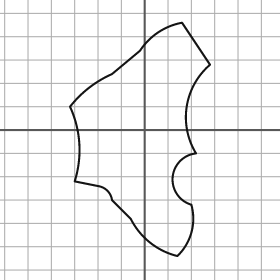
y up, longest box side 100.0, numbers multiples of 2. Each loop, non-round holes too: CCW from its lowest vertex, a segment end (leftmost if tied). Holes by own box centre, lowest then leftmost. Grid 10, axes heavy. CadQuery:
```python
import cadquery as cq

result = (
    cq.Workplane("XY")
    .moveTo(14.0, -54.0)
    .threePointArc((20.0, -44.0), (20.0, -32.0))
    .threePointArc((12.0, -20.0), (22.0, -10.0))
    .threePointArc((18.0, 10.0), (28.0, 28.0))
    .lineTo(16.0, 46.0)
    .threePointArc((6.0, 42.0), (-2.0, 34.0))
    .lineTo(-14.0, 24.0)
    .threePointArc((-24.0, 18.0), (-32.0, 10.0))
    .threePointArc((-28.0, -6.0), (-30.0, -22.0))
    .lineTo(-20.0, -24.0)
    .threePointArc((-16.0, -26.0), (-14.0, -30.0))
    .lineTo(-6.0, -38.0)
    .threePointArc((2.0, -48.0), (14.0, -54.0))
    .close()
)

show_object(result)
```